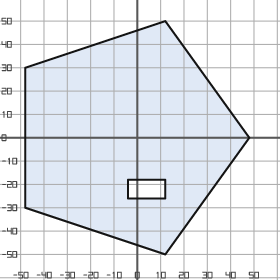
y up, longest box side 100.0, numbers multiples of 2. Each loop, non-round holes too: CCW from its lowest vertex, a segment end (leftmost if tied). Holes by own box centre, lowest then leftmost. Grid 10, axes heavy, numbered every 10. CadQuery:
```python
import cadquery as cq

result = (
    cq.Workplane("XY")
    .moveTo(12.0, -50.0)
    .lineTo(48.0, 0.0)
    .lineTo(12.0, 50.0)
    .lineTo(-48.0, 30.0)
    .lineTo(-48.0, -30.0)
    .close()
    .moveTo(-4.0, -26.0)
    .lineTo(12.0, -26.0)
    .lineTo(12.0, -18.0)
    .lineTo(-4.0, -18.0)
    .close()
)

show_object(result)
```